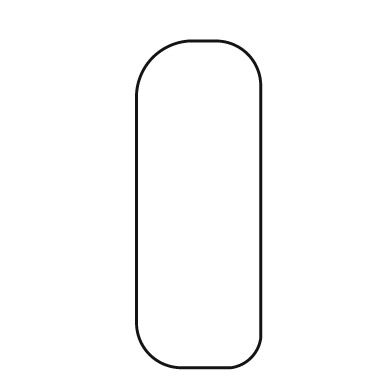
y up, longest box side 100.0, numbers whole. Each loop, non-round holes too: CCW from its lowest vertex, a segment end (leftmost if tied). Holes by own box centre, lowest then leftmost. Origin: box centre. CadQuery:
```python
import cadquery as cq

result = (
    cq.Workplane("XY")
    .moveTo(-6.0, -50.0)
    .lineTo(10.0, -50.0)
    .threePointArc((16.0, -47.0), (19.0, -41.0))
    .lineTo(19.0, 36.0)
    .threePointArc((15.0, 46.0), (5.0, 50.0))
    .lineTo(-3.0, 50.0)
    .threePointArc((-14.0, 45.0), (-19.0, 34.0))
    .lineTo(-19.0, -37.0)
    .threePointArc((-15.0, -46.0), (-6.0, -50.0))
    .close()
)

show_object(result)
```